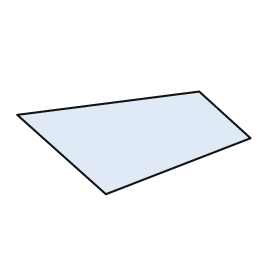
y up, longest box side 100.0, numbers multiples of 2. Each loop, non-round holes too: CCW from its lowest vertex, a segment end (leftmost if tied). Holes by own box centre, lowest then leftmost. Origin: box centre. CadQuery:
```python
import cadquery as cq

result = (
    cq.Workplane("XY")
    .moveTo(-12.0, -22.0)
    .lineTo(50.0, 2.0)
    .lineTo(28.0, 22.0)
    .lineTo(-50.0, 12.0)
    .close()
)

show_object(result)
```